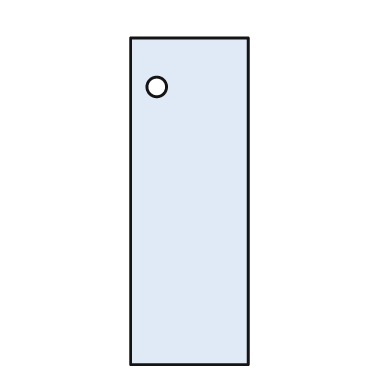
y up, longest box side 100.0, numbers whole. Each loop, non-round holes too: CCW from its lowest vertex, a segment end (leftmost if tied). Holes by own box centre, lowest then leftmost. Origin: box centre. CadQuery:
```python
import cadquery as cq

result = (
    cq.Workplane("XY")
    .moveTo(-18.0, -50.0)
    .lineTo(18.0, -50.0)
    .lineTo(18.0, 50.0)
    .lineTo(-18.0, 50.0)
    .close()
    .moveTo(-10.0, 35.0)
    .circle(3.0)
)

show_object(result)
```